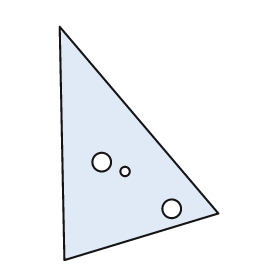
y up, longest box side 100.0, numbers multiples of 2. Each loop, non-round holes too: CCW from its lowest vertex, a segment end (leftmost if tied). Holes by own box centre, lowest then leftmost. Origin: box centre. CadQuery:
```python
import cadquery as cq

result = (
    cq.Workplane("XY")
    .moveTo(-32.0, -50.0)
    .lineTo(34.0, -30.0)
    .lineTo(-34.0, 50.0)
    .close()
    .moveTo(14.0, -28.0)
    .circle(4.0)
    .moveTo(-6.0, -12.0)
    .circle(2.0)
    .moveTo(-16.0, -8.0)
    .circle(4.0)
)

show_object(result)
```